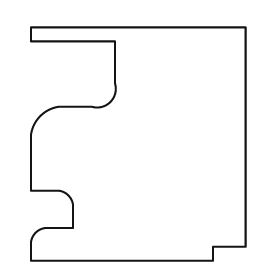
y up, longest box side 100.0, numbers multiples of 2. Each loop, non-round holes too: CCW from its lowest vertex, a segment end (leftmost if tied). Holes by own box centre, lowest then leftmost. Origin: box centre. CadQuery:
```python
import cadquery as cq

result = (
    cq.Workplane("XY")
    .moveTo(-46.0, -50.0)
    .lineTo(32.0, -50.0)
    .lineTo(32.0, -44.0)
    .lineTo(46.0, -44.0)
    .lineTo(46.0, 50.0)
    .lineTo(-46.0, 50.0)
    .lineTo(-46.0, 44.0)
    .lineTo(-10.0, 44.0)
    .lineTo(-10.0, 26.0)
    .threePointArc((-12.0, 18.0), (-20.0, 16.0))
    .lineTo(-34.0, 16.0)
    .threePointArc((-42.0, 12.0), (-46.0, 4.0))
    .lineTo(-46.0, -20.0)
    .lineTo(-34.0, -20.0)
    .threePointArc((-30.0, -22.0), (-28.0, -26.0))
    .lineTo(-28.0, -36.0)
    .lineTo(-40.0, -36.0)
    .threePointArc((-44.0, -38.0), (-46.0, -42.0))
    .close()
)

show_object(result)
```